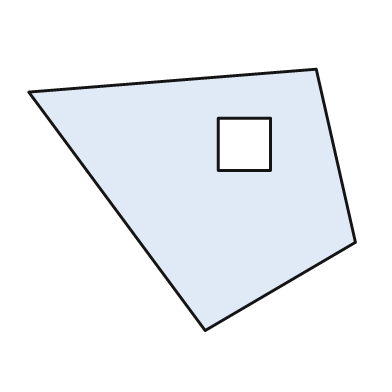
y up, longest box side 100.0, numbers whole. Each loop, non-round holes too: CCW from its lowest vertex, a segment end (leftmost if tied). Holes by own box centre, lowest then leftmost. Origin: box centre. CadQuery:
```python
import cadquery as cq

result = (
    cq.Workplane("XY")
    .moveTo(4.0, -40.0)
    .lineTo(50.0, -13.0)
    .lineTo(38.0, 40.0)
    .lineTo(-50.0, 33.0)
    .close()
    .moveTo(8.0, 9.0)
    .lineTo(24.0, 9.0)
    .lineTo(24.0, 25.0)
    .lineTo(8.0, 25.0)
    .close()
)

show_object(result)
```